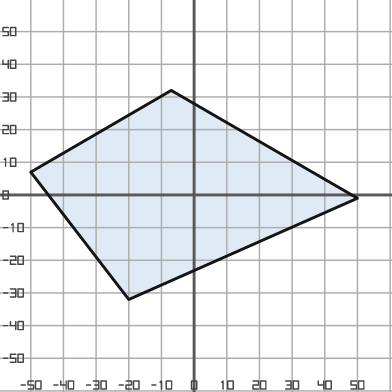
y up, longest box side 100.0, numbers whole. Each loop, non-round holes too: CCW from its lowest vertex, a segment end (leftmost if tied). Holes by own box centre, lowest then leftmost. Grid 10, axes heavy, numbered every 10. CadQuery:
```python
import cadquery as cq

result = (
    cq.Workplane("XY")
    .moveTo(-20.0, -32.0)
    .lineTo(50.0, -1.0)
    .lineTo(-7.0, 32.0)
    .lineTo(-50.0, 7.0)
    .close()
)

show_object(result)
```